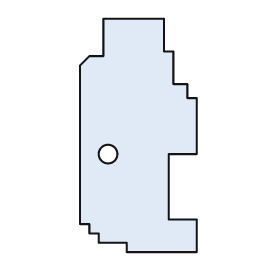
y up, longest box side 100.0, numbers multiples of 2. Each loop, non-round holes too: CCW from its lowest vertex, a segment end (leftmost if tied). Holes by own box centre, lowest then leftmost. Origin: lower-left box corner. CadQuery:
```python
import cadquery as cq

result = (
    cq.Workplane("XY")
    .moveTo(20.0, 0.0)
    .lineTo(50.0, 0.0)
    .lineTo(50.0, 14.0)
    .lineTo(38.0, 14.0)
    .lineTo(38.0, 42.0)
    .lineTo(50.0, 42.0)
    .lineTo(50.0, 66.0)
    .lineTo(46.0, 66.0)
    .lineTo(46.0, 72.0)
    .lineTo(40.0, 72.0)
    .lineTo(40.0, 86.0)
    .lineTo(36.0, 86.0)
    .lineTo(36.0, 100.0)
    .lineTo(10.0, 100.0)
    .lineTo(10.0, 84.0)
    .lineTo(4.0, 84.0)
    .lineTo(0.0, 80.0)
    .lineTo(0.0, 12.0)
    .lineTo(4.0, 12.0)
    .lineTo(4.0, 8.0)
    .lineTo(8.0, 8.0)
    .lineTo(8.0, 4.0)
    .lineTo(20.0, 4.0)
    .close()
    .moveTo(12.0, 42.0)
    .circle(4.0)
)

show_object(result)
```